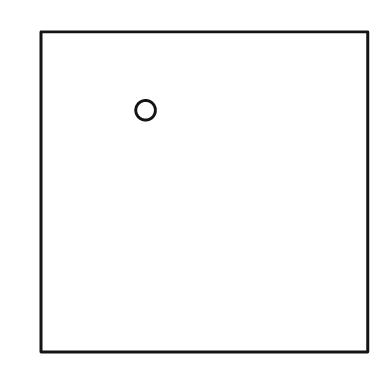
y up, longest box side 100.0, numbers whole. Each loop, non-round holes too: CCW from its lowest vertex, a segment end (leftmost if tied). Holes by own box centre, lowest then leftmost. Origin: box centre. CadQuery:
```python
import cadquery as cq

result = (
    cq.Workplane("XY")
    .moveTo(-50.0, -49.0)
    .lineTo(50.0, -49.0)
    .lineTo(50.0, 49.0)
    .lineTo(-50.0, 49.0)
    .close()
    .moveTo(-18.0, 25.0)
    .circle(3.0)
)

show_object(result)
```